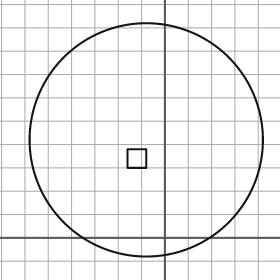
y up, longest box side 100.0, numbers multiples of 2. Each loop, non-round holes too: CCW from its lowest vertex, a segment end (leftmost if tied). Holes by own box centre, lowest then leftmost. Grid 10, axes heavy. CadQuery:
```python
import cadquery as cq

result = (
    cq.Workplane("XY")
    .moveTo(-8.0, 42.0)
    .circle(50.0)
    .moveTo(-16.0, 30.0)
    .lineTo(-8.0, 30.0)
    .lineTo(-8.0, 38.0)
    .lineTo(-16.0, 38.0)
    .close()
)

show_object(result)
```